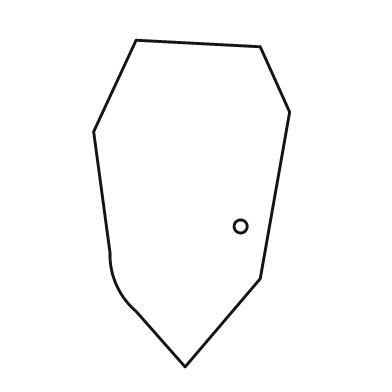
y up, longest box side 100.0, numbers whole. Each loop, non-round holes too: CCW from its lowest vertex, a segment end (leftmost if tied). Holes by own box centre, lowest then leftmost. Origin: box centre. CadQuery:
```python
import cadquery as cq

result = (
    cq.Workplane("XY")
    .moveTo(-2.0, -50.0)
    .lineTo(21.0, -23.0)
    .lineTo(30.0, 28.0)
    .lineTo(21.0, 48.0)
    .lineTo(-17.0, 50.0)
    .lineTo(-30.0, 22.0)
    .lineTo(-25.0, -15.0)
    .threePointArc((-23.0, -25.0), (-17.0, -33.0))
    .close()
    .moveTo(15.0, -7.0)
    .circle(2.0)
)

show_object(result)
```